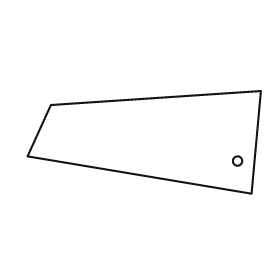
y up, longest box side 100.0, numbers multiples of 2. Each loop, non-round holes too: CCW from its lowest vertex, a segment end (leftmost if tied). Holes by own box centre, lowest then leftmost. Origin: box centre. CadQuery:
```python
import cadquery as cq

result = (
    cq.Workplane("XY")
    .moveTo(46.0, -22.0)
    .lineTo(50.0, 22.0)
    .lineTo(-40.0, 16.0)
    .lineTo(-50.0, -6.0)
    .close()
    .moveTo(40.0, -8.0)
    .circle(2.0)
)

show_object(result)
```